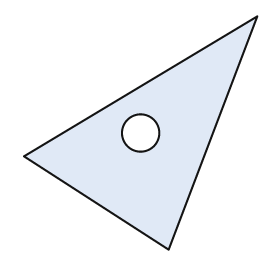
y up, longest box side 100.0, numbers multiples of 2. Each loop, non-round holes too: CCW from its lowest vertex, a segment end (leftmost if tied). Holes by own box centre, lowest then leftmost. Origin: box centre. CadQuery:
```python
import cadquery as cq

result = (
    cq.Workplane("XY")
    .moveTo(12.0, -50.0)
    .lineTo(50.0, 50.0)
    .lineTo(-50.0, -10.0)
    .close()
    .moveTo(0.0, 0.0)
    .circle(8.0)
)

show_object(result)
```